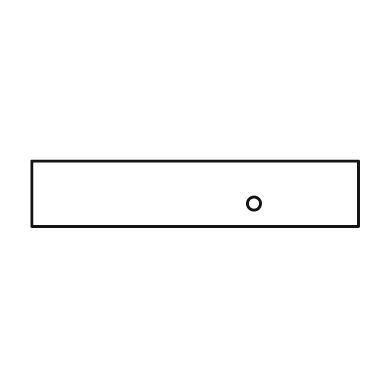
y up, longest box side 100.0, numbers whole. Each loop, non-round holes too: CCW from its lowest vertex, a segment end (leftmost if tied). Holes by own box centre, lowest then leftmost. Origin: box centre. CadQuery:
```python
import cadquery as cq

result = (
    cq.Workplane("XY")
    .moveTo(-50.0, -10.0)
    .lineTo(50.0, -10.0)
    .lineTo(50.0, 10.0)
    .lineTo(-50.0, 10.0)
    .close()
    .moveTo(18.0, -3.0)
    .circle(2.0)
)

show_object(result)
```